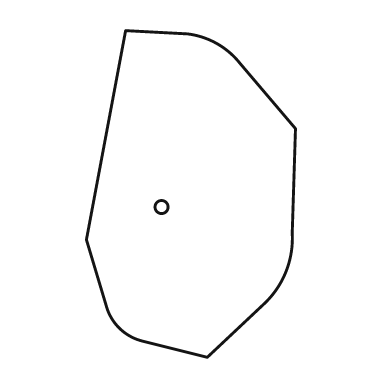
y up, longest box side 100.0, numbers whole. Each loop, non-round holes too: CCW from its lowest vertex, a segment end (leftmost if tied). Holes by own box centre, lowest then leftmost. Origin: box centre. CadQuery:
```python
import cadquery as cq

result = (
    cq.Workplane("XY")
    .moveTo(5.0, -50.0)
    .lineTo(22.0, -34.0)
    .threePointArc((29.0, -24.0), (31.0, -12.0))
    .lineTo(32.0, 20.0)
    .lineTo(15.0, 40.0)
    .threePointArc((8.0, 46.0), (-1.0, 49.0))
    .lineTo(-20.0, 50.0)
    .lineTo(-32.0, -14.0)
    .lineTo(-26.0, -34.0)
    .threePointArc((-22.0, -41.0), (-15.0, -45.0))
    .close()
    .moveTo(-9.0, -4.0)
    .circle(2.0)
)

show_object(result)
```